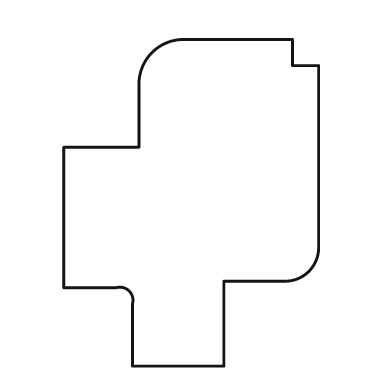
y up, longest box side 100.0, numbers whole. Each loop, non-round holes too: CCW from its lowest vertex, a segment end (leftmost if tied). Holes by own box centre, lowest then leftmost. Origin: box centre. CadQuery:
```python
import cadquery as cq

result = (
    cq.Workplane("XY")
    .moveTo(-18.0, -50.0)
    .lineTo(10.0, -50.0)
    .lineTo(10.0, -24.0)
    .lineTo(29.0, -24.0)
    .threePointArc((36.0, -21.0), (39.0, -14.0))
    .lineTo(39.0, 42.0)
    .lineTo(31.0, 42.0)
    .lineTo(31.0, 50.0)
    .lineTo(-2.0, 50.0)
    .threePointArc((-12.0, 46.0), (-16.0, 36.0))
    .lineTo(-16.0, 17.0)
    .lineTo(-39.0, 17.0)
    .lineTo(-39.0, -26.0)
    .lineTo(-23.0, -26.0)
    .threePointArc((-19.0, -27.0), (-18.0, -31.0))
    .close()
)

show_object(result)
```